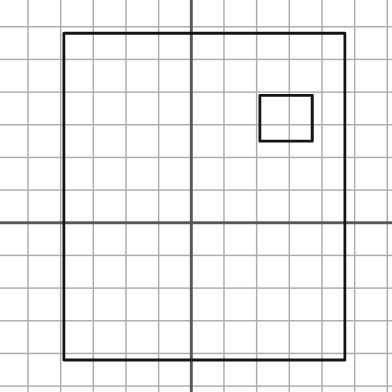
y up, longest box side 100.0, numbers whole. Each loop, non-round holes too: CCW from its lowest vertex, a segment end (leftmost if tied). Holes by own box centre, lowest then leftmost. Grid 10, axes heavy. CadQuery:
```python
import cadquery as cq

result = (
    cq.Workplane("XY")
    .moveTo(-39.0, -42.0)
    .lineTo(47.0, -42.0)
    .lineTo(47.0, 58.0)
    .lineTo(-39.0, 58.0)
    .close()
    .moveTo(21.0, 25.0)
    .lineTo(37.0, 25.0)
    .lineTo(37.0, 39.0)
    .lineTo(21.0, 39.0)
    .close()
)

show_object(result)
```